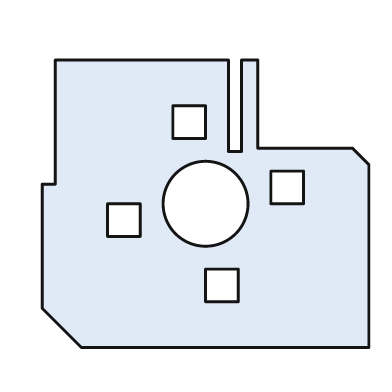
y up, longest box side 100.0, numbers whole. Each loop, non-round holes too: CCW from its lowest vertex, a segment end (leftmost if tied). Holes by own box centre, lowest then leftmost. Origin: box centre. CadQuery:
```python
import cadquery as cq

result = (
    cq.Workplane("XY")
    .moveTo(-38.0, -44.0)
    .lineTo(50.0, -44.0)
    .lineTo(50.0, 12.0)
    .lineTo(45.0, 17.0)
    .lineTo(16.0, 17.0)
    .lineTo(16.0, 44.0)
    .lineTo(11.0, 44.0)
    .lineTo(11.0, 16.0)
    .lineTo(7.0, 16.0)
    .lineTo(7.0, 44.0)
    .lineTo(-46.0, 44.0)
    .lineTo(-46.0, 6.0)
    .lineTo(-50.0, 6.0)
    .lineTo(-50.0, -32.0)
    .close()
    .moveTo(0.0, -30.0)
    .lineTo(10.0, -30.0)
    .lineTo(10.0, -20.0)
    .lineTo(0.0, -20.0)
    .close()
    .moveTo(-30.0, -10.0)
    .lineTo(-20.0, -10.0)
    .lineTo(-20.0, 0.0)
    .lineTo(-30.0, 0.0)
    .close()
    .moveTo(0.0, 0.0)
    .circle(13.0)
    .moveTo(20.0, 0.0)
    .lineTo(30.0, 0.0)
    .lineTo(30.0, 10.0)
    .lineTo(20.0, 10.0)
    .close()
    .moveTo(-10.0, 20.0)
    .lineTo(0.0, 20.0)
    .lineTo(0.0, 30.0)
    .lineTo(-10.0, 30.0)
    .close()
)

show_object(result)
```